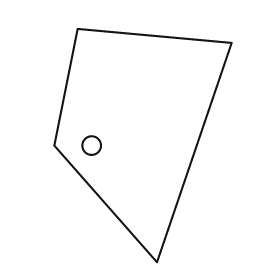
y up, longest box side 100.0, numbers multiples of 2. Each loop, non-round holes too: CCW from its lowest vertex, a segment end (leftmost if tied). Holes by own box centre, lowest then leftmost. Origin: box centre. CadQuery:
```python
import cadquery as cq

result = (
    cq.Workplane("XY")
    .moveTo(6.0, -50.0)
    .lineTo(38.0, 44.0)
    .lineTo(-28.0, 50.0)
    .lineTo(-38.0, 0.0)
    .close()
    .moveTo(-22.0, 0.0)
    .circle(4.0)
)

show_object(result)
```